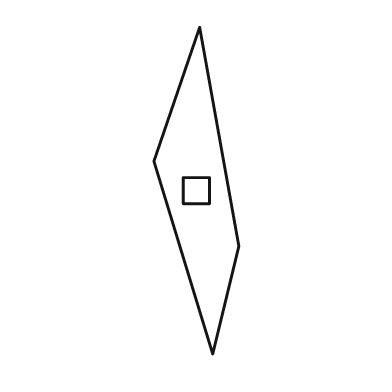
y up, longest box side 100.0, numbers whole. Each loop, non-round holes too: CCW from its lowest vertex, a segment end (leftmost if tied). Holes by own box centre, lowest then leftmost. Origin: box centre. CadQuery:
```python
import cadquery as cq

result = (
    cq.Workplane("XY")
    .moveTo(5.0, -50.0)
    .lineTo(13.0, -17.0)
    .lineTo(1.0, 50.0)
    .lineTo(-13.0, 9.0)
    .close()
    .moveTo(-4.0, -4.0)
    .lineTo(4.0, -4.0)
    .lineTo(4.0, 4.0)
    .lineTo(-4.0, 4.0)
    .close()
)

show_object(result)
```